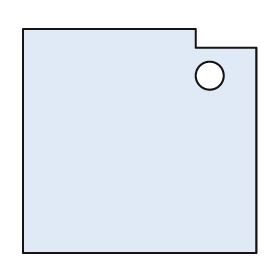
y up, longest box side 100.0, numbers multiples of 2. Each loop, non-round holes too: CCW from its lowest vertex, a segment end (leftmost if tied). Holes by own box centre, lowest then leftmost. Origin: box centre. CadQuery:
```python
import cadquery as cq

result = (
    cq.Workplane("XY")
    .moveTo(-50.0, -48.0)
    .lineTo(50.0, -48.0)
    .lineTo(50.0, 40.0)
    .lineTo(24.0, 40.0)
    .lineTo(24.0, 48.0)
    .lineTo(-50.0, 48.0)
    .close()
    .moveTo(30.0, 28.0)
    .circle(6.0)
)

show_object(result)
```